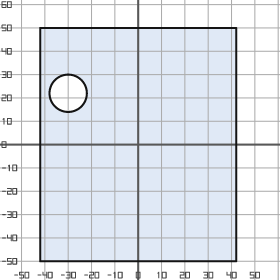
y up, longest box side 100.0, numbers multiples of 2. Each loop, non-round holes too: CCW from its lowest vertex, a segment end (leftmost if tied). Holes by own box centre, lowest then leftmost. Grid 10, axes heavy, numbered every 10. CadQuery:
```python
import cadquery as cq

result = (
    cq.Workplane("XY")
    .moveTo(-42.0, -50.0)
    .lineTo(42.0, -50.0)
    .lineTo(42.0, 50.0)
    .lineTo(-42.0, 50.0)
    .close()
    .moveTo(-30.0, 22.0)
    .circle(8.0)
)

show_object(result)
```